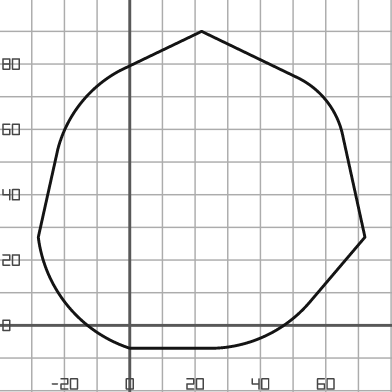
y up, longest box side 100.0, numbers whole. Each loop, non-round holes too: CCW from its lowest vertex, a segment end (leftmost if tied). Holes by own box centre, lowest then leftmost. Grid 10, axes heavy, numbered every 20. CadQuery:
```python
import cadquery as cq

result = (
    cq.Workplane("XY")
    .moveTo(0.0, -7.0)
    .lineTo(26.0, -7.0)
    .threePointArc((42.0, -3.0), (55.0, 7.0))
    .lineTo(72.0, 27.0)
    .lineTo(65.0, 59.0)
    .threePointArc((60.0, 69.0), (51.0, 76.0))
    .lineTo(22.0, 90.0)
    .lineTo(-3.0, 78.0)
    .threePointArc((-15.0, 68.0), (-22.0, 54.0))
    .lineTo(-28.0, 27.0)
    .threePointArc((-19.0, 6.0), (0.0, -7.0))
    .close()
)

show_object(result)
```